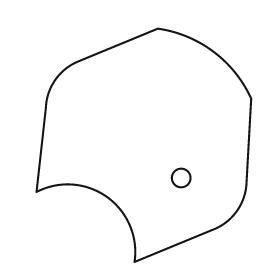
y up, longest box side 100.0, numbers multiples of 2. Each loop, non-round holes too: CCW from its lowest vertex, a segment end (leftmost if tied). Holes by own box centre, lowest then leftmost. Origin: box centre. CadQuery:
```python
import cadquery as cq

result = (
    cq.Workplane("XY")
    .moveTo(-4.0, -50.0)
    .lineTo(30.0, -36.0)
    .threePointArc((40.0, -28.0), (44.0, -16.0))
    .lineTo(46.0, 20.0)
    .threePointArc((30.0, 40.0), (6.0, 50.0))
    .lineTo(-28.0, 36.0)
    .threePointArc((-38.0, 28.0), (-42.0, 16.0))
    .lineTo(-46.0, -20.0)
    .threePointArc((-16.0, -22.0), (-4.0, -50.0))
    .close()
    .moveTo(16.0, -14.0)
    .circle(4.0)
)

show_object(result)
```